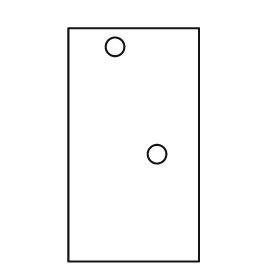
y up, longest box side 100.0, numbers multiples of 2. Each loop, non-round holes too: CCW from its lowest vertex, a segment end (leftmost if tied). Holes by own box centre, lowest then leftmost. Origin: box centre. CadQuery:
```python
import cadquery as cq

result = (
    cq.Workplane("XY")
    .moveTo(-28.0, -50.0)
    .lineTo(28.0, -50.0)
    .lineTo(28.0, 50.0)
    .lineTo(-28.0, 50.0)
    .close()
    .moveTo(10.0, -4.0)
    .circle(4.0)
    .moveTo(-8.0, 42.0)
    .circle(4.0)
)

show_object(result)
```